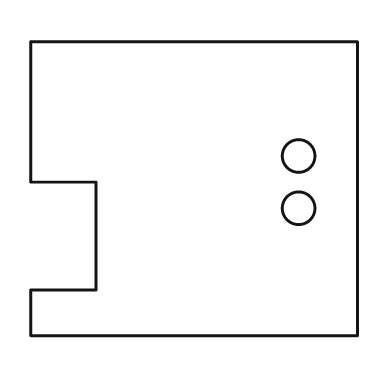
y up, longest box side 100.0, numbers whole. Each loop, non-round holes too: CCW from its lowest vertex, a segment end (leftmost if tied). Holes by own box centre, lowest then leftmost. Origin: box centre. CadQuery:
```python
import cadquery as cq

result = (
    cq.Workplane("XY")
    .moveTo(-50.0, -45.0)
    .lineTo(50.0, -45.0)
    .lineTo(50.0, 45.0)
    .lineTo(-50.0, 45.0)
    .lineTo(-50.0, 2.0)
    .lineTo(-30.0, 2.0)
    .lineTo(-30.0, -31.0)
    .lineTo(-50.0, -31.0)
    .close()
    .moveTo(32.0, -6.0)
    .circle(5.0)
    .moveTo(32.0, 10.0)
    .circle(5.0)
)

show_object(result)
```